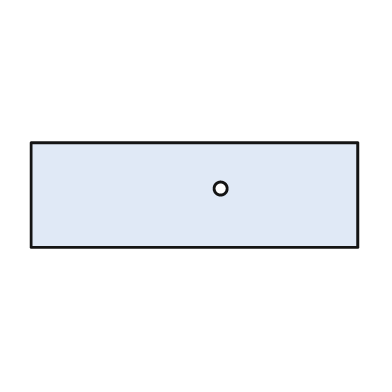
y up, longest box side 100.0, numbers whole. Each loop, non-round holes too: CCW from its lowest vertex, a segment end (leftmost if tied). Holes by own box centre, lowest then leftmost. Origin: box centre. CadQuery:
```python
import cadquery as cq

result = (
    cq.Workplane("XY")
    .moveTo(-50.0, -16.0)
    .lineTo(50.0, -16.0)
    .lineTo(50.0, 16.0)
    .lineTo(-50.0, 16.0)
    .close()
    .moveTo(8.0, 2.0)
    .circle(2.0)
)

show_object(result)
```